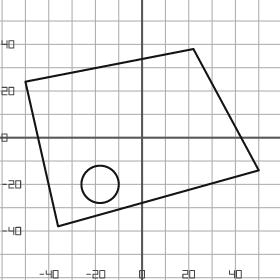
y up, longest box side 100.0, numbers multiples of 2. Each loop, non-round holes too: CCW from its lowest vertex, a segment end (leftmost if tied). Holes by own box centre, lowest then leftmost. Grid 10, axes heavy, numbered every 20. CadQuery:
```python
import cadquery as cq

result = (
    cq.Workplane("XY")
    .moveTo(-36.0, -38.0)
    .lineTo(50.0, -14.0)
    .lineTo(22.0, 38.0)
    .lineTo(-50.0, 24.0)
    .close()
    .moveTo(-18.0, -20.0)
    .circle(8.0)
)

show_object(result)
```